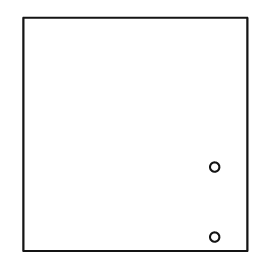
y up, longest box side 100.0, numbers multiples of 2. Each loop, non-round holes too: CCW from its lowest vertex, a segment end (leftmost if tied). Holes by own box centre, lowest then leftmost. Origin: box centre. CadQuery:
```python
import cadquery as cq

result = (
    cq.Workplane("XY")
    .moveTo(-48.0, -50.0)
    .lineTo(48.0, -50.0)
    .lineTo(48.0, 50.0)
    .lineTo(-48.0, 50.0)
    .close()
    .moveTo(34.0, -44.0)
    .circle(2.0)
    .moveTo(34.0, -14.0)
    .circle(2.0)
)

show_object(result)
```